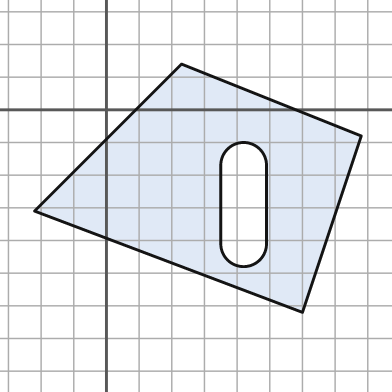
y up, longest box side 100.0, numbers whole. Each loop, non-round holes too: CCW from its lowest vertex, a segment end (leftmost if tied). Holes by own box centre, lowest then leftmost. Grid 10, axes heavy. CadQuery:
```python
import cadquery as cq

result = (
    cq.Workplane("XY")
    .moveTo(60.0, -62.0)
    .lineTo(78.0, -8.0)
    .lineTo(23.0, 14.0)
    .lineTo(-22.0, -31.0)
    .close()
    .moveTo(35.0, -41.0)
    .threePointArc((42.0, -48.0), (49.0, -41.0))
    .lineTo(49.0, -17.0)
    .threePointArc((42.0, -10.0), (35.0, -17.0))
    .close()
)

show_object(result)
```